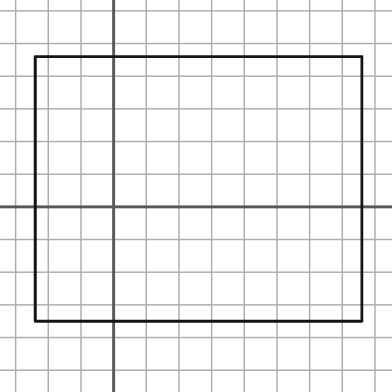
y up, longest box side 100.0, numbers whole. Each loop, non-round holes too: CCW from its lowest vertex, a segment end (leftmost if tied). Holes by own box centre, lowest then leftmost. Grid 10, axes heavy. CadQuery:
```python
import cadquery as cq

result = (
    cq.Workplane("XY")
    .moveTo(-24.0, -35.0)
    .lineTo(76.0, -35.0)
    .lineTo(76.0, 46.0)
    .lineTo(-24.0, 46.0)
    .close()
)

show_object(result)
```